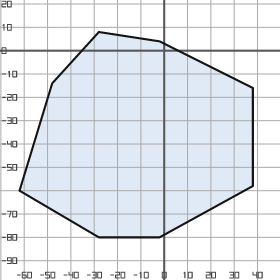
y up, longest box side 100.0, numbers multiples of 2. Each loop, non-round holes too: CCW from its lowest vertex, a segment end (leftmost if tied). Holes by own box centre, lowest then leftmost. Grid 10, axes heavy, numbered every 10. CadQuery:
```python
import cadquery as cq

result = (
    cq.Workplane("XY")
    .moveTo(-28.0, -80.0)
    .lineTo(-2.0, -80.0)
    .lineTo(38.0, -58.0)
    .lineTo(38.0, -16.0)
    .lineTo(-2.0, 4.0)
    .lineTo(-28.0, 8.0)
    .lineTo(-48.0, -14.0)
    .lineTo(-62.0, -60.0)
    .close()
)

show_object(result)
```